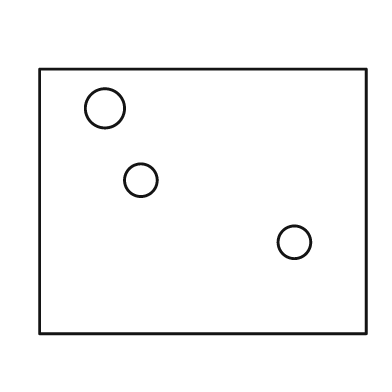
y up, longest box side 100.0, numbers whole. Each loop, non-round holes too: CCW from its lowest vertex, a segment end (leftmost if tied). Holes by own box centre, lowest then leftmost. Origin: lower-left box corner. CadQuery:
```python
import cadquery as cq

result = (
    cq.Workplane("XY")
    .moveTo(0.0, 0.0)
    .lineTo(100.0, 0.0)
    .lineTo(100.0, 81.0)
    .lineTo(0.0, 81.0)
    .close()
    .moveTo(78.0, 28.0)
    .circle(5.0)
    .moveTo(31.0, 47.0)
    .circle(5.0)
    .moveTo(20.0, 69.0)
    .circle(6.0)
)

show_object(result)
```